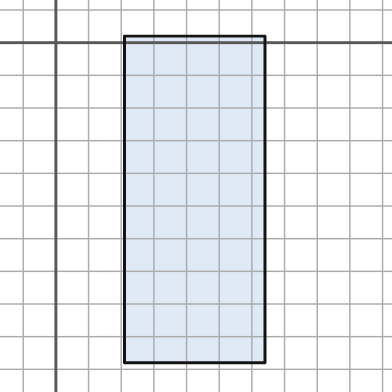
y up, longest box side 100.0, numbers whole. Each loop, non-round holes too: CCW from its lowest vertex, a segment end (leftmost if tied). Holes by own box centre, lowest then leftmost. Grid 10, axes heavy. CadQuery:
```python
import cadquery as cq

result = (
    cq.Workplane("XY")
    .moveTo(21.0, -98.0)
    .lineTo(64.0, -98.0)
    .lineTo(64.0, 2.0)
    .lineTo(21.0, 2.0)
    .close()
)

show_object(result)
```